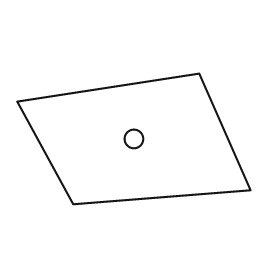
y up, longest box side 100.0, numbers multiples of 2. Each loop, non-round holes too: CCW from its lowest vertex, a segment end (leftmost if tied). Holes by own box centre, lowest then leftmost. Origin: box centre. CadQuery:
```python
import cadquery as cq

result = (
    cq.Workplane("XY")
    .moveTo(-26.0, -28.0)
    .lineTo(50.0, -22.0)
    .lineTo(28.0, 28.0)
    .lineTo(-50.0, 16.0)
    .close()
    .moveTo(0.0, 0.0)
    .circle(4.0)
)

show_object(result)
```